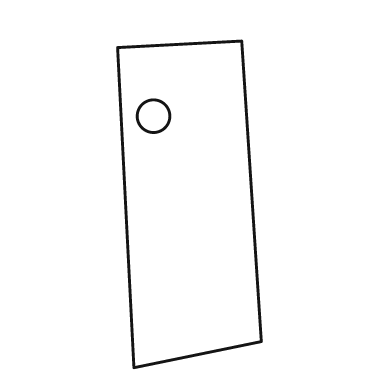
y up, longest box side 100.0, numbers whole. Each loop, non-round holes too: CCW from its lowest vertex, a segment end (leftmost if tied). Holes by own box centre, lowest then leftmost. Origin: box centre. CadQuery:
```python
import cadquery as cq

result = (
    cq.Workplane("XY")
    .moveTo(-17.0, -50.0)
    .lineTo(22.0, -42.0)
    .lineTo(16.0, 50.0)
    .lineTo(-22.0, 48.0)
    .close()
    .moveTo(-11.0, 27.0)
    .circle(5.0)
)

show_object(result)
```